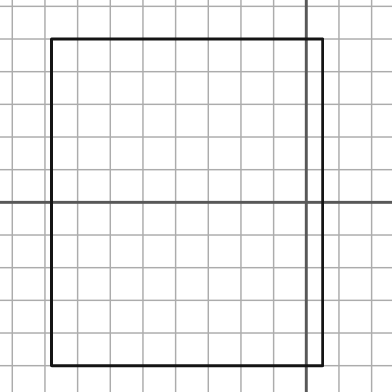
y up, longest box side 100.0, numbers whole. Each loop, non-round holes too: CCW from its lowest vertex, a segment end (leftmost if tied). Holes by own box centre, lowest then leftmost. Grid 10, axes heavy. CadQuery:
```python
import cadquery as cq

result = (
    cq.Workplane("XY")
    .moveTo(-78.0, -50.0)
    .lineTo(5.0, -50.0)
    .lineTo(5.0, 50.0)
    .lineTo(-78.0, 50.0)
    .close()
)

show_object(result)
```